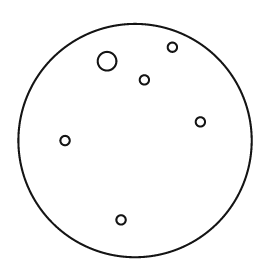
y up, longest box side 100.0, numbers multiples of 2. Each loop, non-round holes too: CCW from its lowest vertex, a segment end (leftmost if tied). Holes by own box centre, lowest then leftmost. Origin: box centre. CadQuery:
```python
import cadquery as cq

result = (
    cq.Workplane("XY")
    .moveTo(0.0, 0.0)
    .circle(50.0)
    .moveTo(-6.0, -34.0)
    .circle(2.0)
    .moveTo(-30.0, 0.0)
    .circle(2.0)
    .moveTo(28.0, 8.0)
    .circle(2.0)
    .moveTo(4.0, 26.0)
    .circle(2.0)
    .moveTo(-12.0, 34.0)
    .circle(4.0)
    .moveTo(16.0, 40.0)
    .circle(2.0)
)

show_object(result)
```